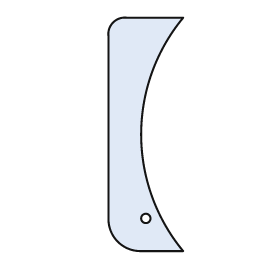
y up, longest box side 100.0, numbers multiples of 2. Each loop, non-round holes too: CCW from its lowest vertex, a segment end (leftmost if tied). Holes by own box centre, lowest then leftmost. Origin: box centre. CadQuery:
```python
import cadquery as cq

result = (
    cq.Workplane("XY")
    .moveTo(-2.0, -50.0)
    .lineTo(16.0, -50.0)
    .threePointArc((-2.0, 0.0), (16.0, 50.0))
    .lineTo(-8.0, 50.0)
    .threePointArc((-14.0, 48.0), (-16.0, 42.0))
    .lineTo(-16.0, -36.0)
    .threePointArc((-12.0, -46.0), (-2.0, -50.0))
    .close()
    .moveTo(0.0, -36.0)
    .circle(2.0)
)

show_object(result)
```